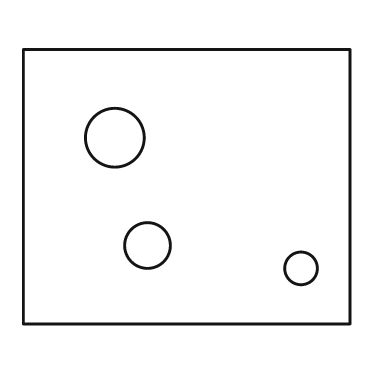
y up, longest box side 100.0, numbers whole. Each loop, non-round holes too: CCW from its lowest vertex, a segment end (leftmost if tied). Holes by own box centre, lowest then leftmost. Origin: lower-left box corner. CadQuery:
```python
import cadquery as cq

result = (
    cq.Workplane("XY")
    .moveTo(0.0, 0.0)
    .lineTo(100.0, 0.0)
    .lineTo(100.0, 84.0)
    .lineTo(0.0, 84.0)
    .close()
    .moveTo(85.0, 17.0)
    .circle(5.0)
    .moveTo(38.0, 24.0)
    .circle(7.0)
    .moveTo(28.0, 57.0)
    .circle(9.0)
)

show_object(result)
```